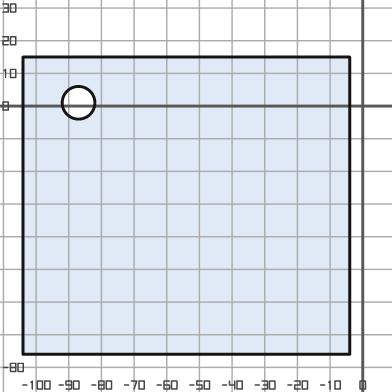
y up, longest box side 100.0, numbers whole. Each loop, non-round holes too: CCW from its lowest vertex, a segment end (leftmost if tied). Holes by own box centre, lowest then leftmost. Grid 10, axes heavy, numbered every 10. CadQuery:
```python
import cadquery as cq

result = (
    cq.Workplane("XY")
    .moveTo(-104.0, -76.0)
    .lineTo(-4.0, -76.0)
    .lineTo(-4.0, 15.0)
    .lineTo(-104.0, 15.0)
    .close()
    .moveTo(-87.0, 1.0)
    .circle(5.0)
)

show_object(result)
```